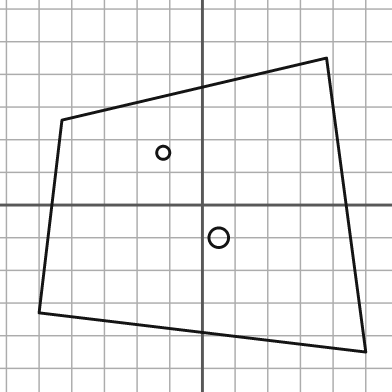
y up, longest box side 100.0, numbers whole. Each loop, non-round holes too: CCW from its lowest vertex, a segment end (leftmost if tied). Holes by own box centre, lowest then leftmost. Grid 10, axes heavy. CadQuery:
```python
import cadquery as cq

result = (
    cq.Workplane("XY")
    .moveTo(50.0, -45.0)
    .lineTo(38.0, 45.0)
    .lineTo(-43.0, 26.0)
    .lineTo(-50.0, -33.0)
    .close()
    .moveTo(5.0, -10.0)
    .circle(3.0)
    .moveTo(-12.0, 16.0)
    .circle(2.0)
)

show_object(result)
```